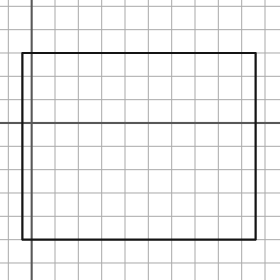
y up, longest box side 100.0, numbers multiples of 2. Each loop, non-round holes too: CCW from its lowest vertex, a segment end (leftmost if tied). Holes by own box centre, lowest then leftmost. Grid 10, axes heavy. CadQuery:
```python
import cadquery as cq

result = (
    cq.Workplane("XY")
    .moveTo(-4.0, -50.0)
    .lineTo(96.0, -50.0)
    .lineTo(96.0, 30.0)
    .lineTo(-4.0, 30.0)
    .close()
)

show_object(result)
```